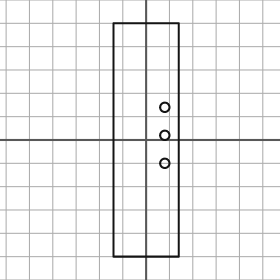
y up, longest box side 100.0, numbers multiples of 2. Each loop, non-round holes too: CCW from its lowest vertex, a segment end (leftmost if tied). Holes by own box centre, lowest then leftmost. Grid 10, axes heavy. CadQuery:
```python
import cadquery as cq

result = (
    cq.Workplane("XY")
    .moveTo(-14.0, -50.0)
    .lineTo(14.0, -50.0)
    .lineTo(14.0, 50.0)
    .lineTo(-14.0, 50.0)
    .close()
    .moveTo(8.0, -10.0)
    .circle(2.0)
    .moveTo(8.0, 2.0)
    .circle(2.0)
    .moveTo(8.0, 14.0)
    .circle(2.0)
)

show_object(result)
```